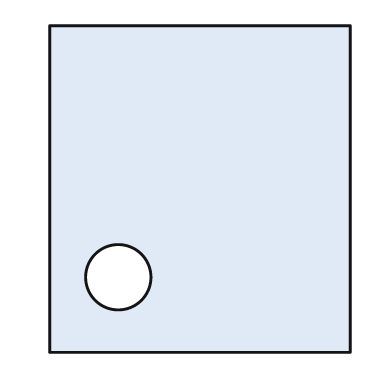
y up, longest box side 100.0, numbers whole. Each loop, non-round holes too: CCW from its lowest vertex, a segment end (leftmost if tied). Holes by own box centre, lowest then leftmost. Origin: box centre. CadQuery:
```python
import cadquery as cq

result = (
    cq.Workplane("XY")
    .moveTo(-46.0, -50.0)
    .lineTo(46.0, -50.0)
    .lineTo(46.0, 50.0)
    .lineTo(-46.0, 50.0)
    .close()
    .moveTo(-25.0, -27.0)
    .circle(10.0)
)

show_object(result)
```